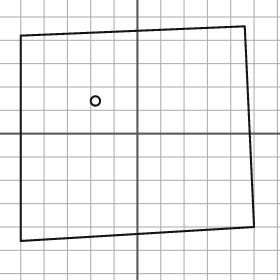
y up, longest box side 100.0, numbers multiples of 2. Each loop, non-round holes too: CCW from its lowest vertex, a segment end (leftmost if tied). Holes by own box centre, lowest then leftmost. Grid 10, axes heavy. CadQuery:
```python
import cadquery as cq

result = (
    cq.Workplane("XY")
    .moveTo(-50.0, -46.0)
    .lineTo(50.0, -40.0)
    .lineTo(46.0, 46.0)
    .lineTo(-50.0, 42.0)
    .close()
    .moveTo(-18.0, 14.0)
    .circle(2.0)
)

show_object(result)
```